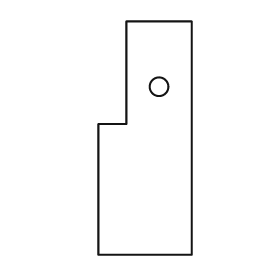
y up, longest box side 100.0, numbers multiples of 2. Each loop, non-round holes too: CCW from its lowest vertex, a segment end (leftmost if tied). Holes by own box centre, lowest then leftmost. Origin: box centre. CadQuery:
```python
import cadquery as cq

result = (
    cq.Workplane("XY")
    .moveTo(-20.0, -50.0)
    .lineTo(20.0, -50.0)
    .lineTo(20.0, 50.0)
    .lineTo(-8.0, 50.0)
    .lineTo(-8.0, 6.0)
    .lineTo(-20.0, 6.0)
    .close()
    .moveTo(6.0, 22.0)
    .circle(4.0)
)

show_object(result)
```